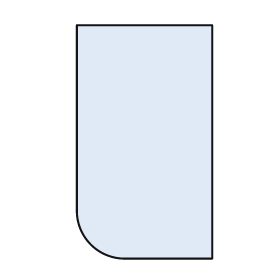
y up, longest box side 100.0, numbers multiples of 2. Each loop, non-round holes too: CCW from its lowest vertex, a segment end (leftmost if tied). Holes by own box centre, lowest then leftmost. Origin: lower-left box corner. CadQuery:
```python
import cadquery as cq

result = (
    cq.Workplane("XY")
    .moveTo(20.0, 0.0)
    .lineTo(58.0, 0.0)
    .lineTo(58.0, 100.0)
    .lineTo(0.0, 100.0)
    .lineTo(0.0, 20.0)
    .threePointArc((6.0, 6.0), (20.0, 0.0))
    .close()
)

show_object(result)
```